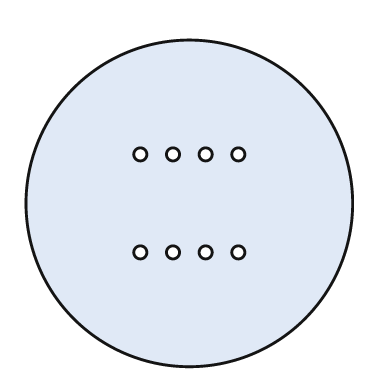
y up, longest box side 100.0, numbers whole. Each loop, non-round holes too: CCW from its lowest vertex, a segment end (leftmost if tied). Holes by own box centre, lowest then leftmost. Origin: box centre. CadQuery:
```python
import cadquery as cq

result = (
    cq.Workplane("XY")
    .moveTo(0.0, 0.0)
    .circle(50.0)
    .moveTo(-15.0, -15.0)
    .circle(2.0)
    .moveTo(-5.0, -15.0)
    .circle(2.0)
    .moveTo(5.0, -15.0)
    .circle(2.0)
    .moveTo(15.0, -15.0)
    .circle(2.0)
    .moveTo(-15.0, 15.0)
    .circle(2.0)
    .moveTo(-5.0, 15.0)
    .circle(2.0)
    .moveTo(5.0, 15.0)
    .circle(2.0)
    .moveTo(15.0, 15.0)
    .circle(2.0)
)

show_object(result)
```